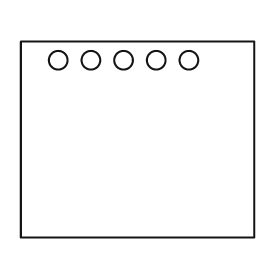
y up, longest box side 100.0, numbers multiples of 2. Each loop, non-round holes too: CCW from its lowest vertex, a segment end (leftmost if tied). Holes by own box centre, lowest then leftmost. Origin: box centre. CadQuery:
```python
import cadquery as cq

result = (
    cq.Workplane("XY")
    .moveTo(-50.0, -42.0)
    .lineTo(50.0, -42.0)
    .lineTo(50.0, 42.0)
    .lineTo(-50.0, 42.0)
    .close()
    .moveTo(-34.0, 34.0)
    .circle(4.0)
    .moveTo(-20.0, 34.0)
    .circle(4.0)
    .moveTo(-6.0, 34.0)
    .circle(4.0)
    .moveTo(8.0, 34.0)
    .circle(4.0)
    .moveTo(22.0, 34.0)
    .circle(4.0)
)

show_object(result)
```